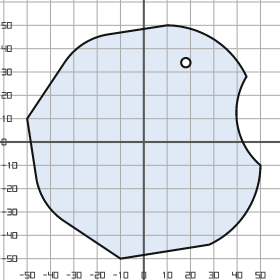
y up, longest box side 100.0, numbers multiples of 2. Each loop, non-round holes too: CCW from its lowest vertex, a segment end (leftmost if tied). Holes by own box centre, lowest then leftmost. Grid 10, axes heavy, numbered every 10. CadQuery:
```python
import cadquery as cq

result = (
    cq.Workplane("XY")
    .moveTo(-10.0, -50.0)
    .lineTo(28.0, -44.0)
    .threePointArc((44.0, -30.0), (50.0, -10.0))
    .threePointArc((40.0, 8.0), (44.0, 28.0))
    .threePointArc((30.0, 44.0), (10.0, 50.0))
    .lineTo(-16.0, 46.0)
    .threePointArc((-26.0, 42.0), (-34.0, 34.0))
    .lineTo(-50.0, 10.0)
    .lineTo(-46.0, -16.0)
    .threePointArc((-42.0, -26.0), (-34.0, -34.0))
    .close()
    .moveTo(18.0, 34.0)
    .circle(2.0)
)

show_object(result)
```